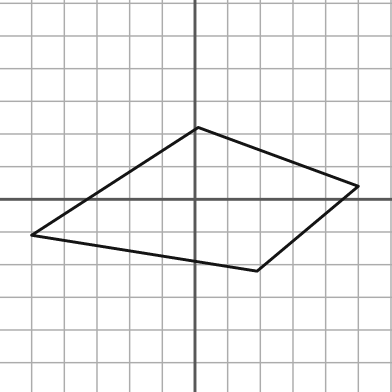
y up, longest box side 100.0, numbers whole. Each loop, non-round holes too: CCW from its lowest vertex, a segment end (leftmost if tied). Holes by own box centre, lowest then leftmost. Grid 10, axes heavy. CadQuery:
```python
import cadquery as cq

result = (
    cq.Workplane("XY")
    .moveTo(19.0, -22.0)
    .lineTo(50.0, 4.0)
    .lineTo(1.0, 22.0)
    .lineTo(-50.0, -11.0)
    .close()
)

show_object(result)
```